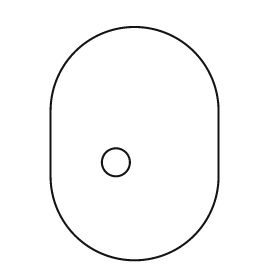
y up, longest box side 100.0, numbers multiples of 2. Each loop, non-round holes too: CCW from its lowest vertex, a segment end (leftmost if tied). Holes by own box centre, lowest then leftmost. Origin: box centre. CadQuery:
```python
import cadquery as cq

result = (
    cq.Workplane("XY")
    .moveTo(-36.0, -14.0)
    .threePointArc((0.0, -50.0), (36.0, -14.0))
    .lineTo(36.0, 14.0)
    .threePointArc((0.0, 50.0), (-36.0, 14.0))
    .close()
    .moveTo(-8.0, -8.0)
    .circle(6.0)
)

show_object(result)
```